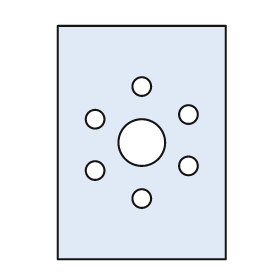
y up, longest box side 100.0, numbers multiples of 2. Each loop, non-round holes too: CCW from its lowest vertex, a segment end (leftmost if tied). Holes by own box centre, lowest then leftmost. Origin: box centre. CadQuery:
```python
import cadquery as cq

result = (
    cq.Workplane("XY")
    .moveTo(-36.0, -50.0)
    .lineTo(36.0, -50.0)
    .lineTo(36.0, 50.0)
    .lineTo(-36.0, 50.0)
    .close()
    .moveTo(0.0, -24.0)
    .circle(4.0)
    .moveTo(-20.0, -12.0)
    .circle(4.0)
    .moveTo(20.0, -10.0)
    .circle(4.0)
    .moveTo(0.0, 0.0)
    .circle(10.0)
    .moveTo(-20.0, 10.0)
    .circle(4.0)
    .moveTo(20.0, 12.0)
    .circle(4.0)
    .moveTo(0.0, 24.0)
    .circle(4.0)
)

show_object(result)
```